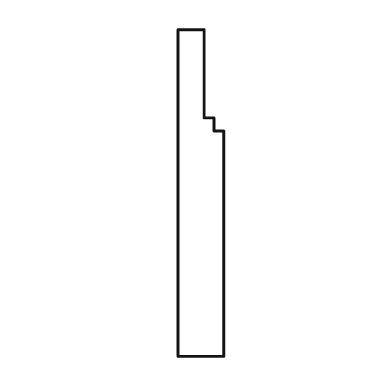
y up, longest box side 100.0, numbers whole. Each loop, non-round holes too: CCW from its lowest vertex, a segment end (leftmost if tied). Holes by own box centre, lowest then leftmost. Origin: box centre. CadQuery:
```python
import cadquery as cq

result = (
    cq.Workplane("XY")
    .moveTo(-7.0, -50.0)
    .lineTo(7.0, -50.0)
    .lineTo(7.0, 19.0)
    .lineTo(4.0, 19.0)
    .lineTo(4.0, 23.0)
    .lineTo(1.0, 23.0)
    .lineTo(1.0, 50.0)
    .lineTo(-7.0, 50.0)
    .close()
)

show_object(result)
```